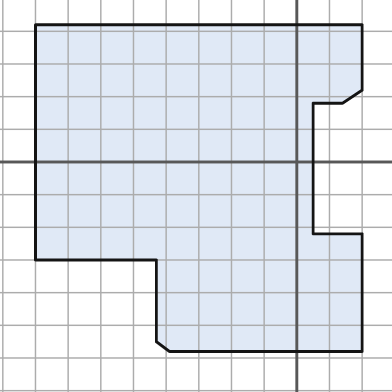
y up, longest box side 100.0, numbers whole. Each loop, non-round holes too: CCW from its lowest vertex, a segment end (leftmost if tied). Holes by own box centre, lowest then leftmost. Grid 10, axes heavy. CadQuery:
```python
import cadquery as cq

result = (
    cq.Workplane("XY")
    .moveTo(-39.0, -58.0)
    .lineTo(20.0, -58.0)
    .lineTo(20.0, -22.0)
    .lineTo(5.0, -22.0)
    .lineTo(5.0, 18.0)
    .lineTo(14.0, 18.0)
    .lineTo(20.0, 22.0)
    .lineTo(20.0, 42.0)
    .lineTo(-80.0, 42.0)
    .lineTo(-80.0, -30.0)
    .lineTo(-43.0, -30.0)
    .lineTo(-43.0, -55.0)
    .close()
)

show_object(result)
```